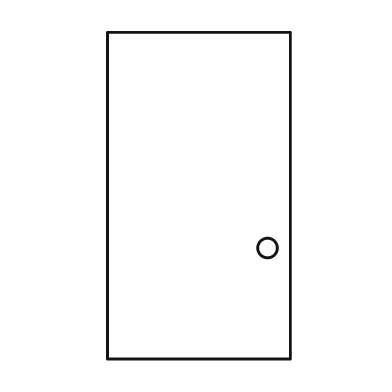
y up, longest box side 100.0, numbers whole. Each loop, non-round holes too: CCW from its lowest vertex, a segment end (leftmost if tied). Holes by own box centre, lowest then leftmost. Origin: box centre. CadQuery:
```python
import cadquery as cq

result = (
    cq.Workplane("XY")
    .moveTo(-28.0, -50.0)
    .lineTo(28.0, -50.0)
    .lineTo(28.0, 50.0)
    .lineTo(-28.0, 50.0)
    .close()
    .moveTo(21.0, -16.0)
    .circle(3.0)
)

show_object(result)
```